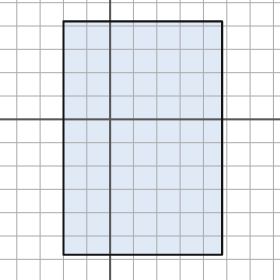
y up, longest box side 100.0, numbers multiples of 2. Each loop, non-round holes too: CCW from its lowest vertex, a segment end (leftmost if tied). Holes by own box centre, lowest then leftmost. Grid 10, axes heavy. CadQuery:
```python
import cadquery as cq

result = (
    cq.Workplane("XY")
    .moveTo(-20.0, -58.0)
    .lineTo(48.0, -58.0)
    .lineTo(48.0, 42.0)
    .lineTo(-20.0, 42.0)
    .close()
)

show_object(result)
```